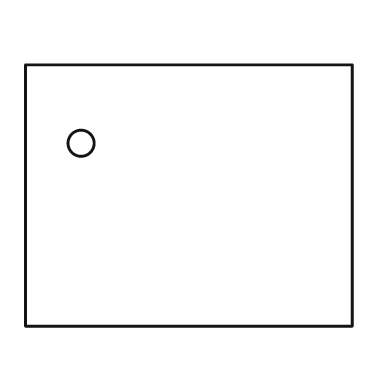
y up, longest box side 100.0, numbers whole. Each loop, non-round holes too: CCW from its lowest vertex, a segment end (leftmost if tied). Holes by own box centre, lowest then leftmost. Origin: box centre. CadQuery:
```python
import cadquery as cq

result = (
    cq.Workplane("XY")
    .moveTo(-50.0, -40.0)
    .lineTo(50.0, -40.0)
    .lineTo(50.0, 40.0)
    .lineTo(-50.0, 40.0)
    .close()
    .moveTo(-33.0, 16.0)
    .circle(4.0)
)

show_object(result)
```